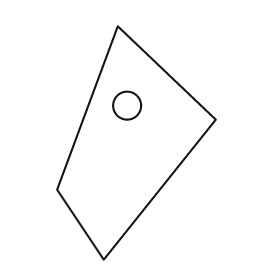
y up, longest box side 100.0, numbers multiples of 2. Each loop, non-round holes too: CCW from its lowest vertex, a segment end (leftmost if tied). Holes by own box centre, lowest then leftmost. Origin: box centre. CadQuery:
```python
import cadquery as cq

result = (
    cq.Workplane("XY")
    .moveTo(-14.0, -50.0)
    .lineTo(34.0, 10.0)
    .lineTo(-8.0, 50.0)
    .lineTo(-34.0, -20.0)
    .close()
    .moveTo(-4.0, 16.0)
    .circle(6.0)
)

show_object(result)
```